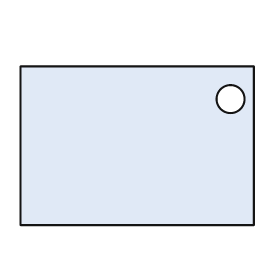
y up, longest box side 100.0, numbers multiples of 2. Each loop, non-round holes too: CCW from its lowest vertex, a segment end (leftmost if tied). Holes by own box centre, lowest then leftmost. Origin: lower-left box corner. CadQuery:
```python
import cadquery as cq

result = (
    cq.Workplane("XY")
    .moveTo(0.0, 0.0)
    .lineTo(100.0, 0.0)
    .lineTo(100.0, 68.0)
    .lineTo(0.0, 68.0)
    .close()
    .moveTo(90.0, 54.0)
    .circle(6.0)
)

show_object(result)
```